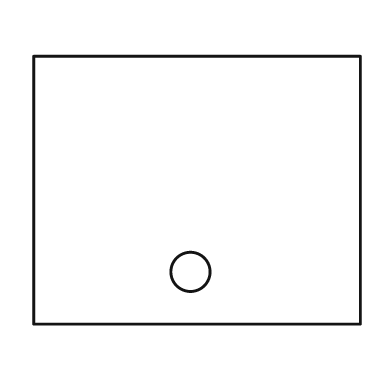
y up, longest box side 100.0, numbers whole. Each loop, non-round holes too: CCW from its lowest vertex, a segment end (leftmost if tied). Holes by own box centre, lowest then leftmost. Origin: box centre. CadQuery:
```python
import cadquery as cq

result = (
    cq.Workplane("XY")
    .moveTo(-50.0, -41.0)
    .lineTo(50.0, -41.0)
    .lineTo(50.0, 41.0)
    .lineTo(-50.0, 41.0)
    .close()
    .moveTo(-2.0, -25.0)
    .circle(6.0)
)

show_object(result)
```